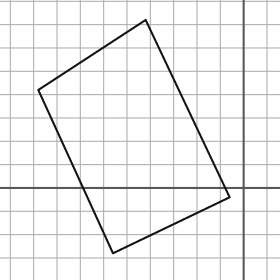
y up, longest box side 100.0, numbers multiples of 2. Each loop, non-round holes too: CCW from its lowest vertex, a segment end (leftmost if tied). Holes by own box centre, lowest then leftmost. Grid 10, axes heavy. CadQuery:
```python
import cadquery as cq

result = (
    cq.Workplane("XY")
    .moveTo(-56.0, -28.0)
    .lineTo(-6.0, -4.0)
    .lineTo(-42.0, 72.0)
    .lineTo(-88.0, 42.0)
    .close()
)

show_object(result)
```